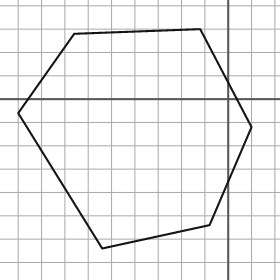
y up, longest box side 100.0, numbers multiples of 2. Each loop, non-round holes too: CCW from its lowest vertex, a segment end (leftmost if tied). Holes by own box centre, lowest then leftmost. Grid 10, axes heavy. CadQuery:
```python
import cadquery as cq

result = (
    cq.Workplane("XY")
    .moveTo(-54.0, -64.0)
    .lineTo(-8.0, -54.0)
    .lineTo(10.0, -12.0)
    .lineTo(-12.0, 30.0)
    .lineTo(-66.0, 28.0)
    .lineTo(-90.0, -6.0)
    .close()
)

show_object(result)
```